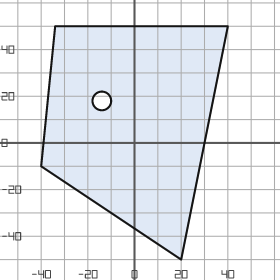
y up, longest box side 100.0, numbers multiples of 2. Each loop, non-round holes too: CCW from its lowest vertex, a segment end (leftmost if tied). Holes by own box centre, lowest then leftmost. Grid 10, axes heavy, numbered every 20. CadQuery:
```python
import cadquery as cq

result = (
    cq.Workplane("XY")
    .moveTo(20.0, -50.0)
    .lineTo(40.0, 50.0)
    .lineTo(-34.0, 50.0)
    .lineTo(-40.0, -10.0)
    .close()
    .moveTo(-14.0, 18.0)
    .circle(4.0)
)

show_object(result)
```